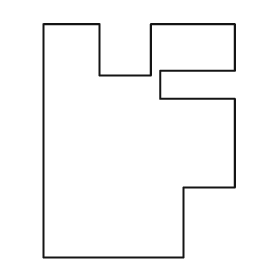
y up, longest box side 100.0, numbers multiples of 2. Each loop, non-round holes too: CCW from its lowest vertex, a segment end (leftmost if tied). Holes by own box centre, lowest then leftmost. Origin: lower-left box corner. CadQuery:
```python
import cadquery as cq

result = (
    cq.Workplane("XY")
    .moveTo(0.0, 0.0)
    .lineTo(60.0, 0.0)
    .lineTo(60.0, 30.0)
    .lineTo(82.0, 30.0)
    .lineTo(82.0, 68.0)
    .lineTo(50.0, 68.0)
    .lineTo(50.0, 80.0)
    .lineTo(82.0, 80.0)
    .lineTo(82.0, 100.0)
    .lineTo(46.0, 100.0)
    .lineTo(46.0, 78.0)
    .lineTo(24.0, 78.0)
    .lineTo(24.0, 100.0)
    .lineTo(0.0, 100.0)
    .close()
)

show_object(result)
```